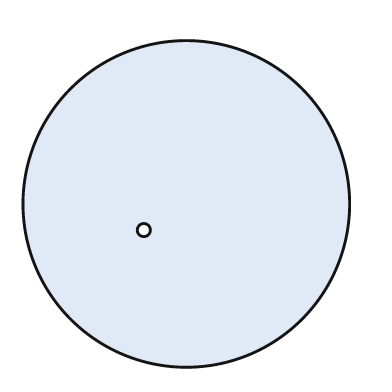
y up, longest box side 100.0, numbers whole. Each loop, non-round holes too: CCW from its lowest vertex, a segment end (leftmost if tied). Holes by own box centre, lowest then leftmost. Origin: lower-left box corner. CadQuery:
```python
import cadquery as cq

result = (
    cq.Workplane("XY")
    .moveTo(50.0, 50.0)
    .circle(50.0)
    .moveTo(37.0, 42.0)
    .circle(2.0)
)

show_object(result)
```